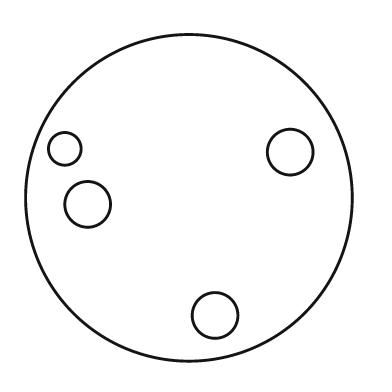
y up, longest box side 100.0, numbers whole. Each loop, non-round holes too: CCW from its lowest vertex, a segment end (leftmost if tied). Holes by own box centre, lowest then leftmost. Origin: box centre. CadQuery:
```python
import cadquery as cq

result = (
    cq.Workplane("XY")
    .moveTo(0.0, 0.0)
    .circle(50.0)
    .moveTo(8.0, -36.0)
    .circle(7.0)
    .moveTo(-31.0, -2.0)
    .circle(7.0)
    .moveTo(31.0, 14.0)
    .circle(7.0)
    .moveTo(-38.0, 15.0)
    .circle(5.0)
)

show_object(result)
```